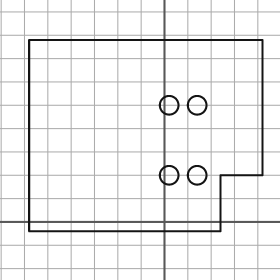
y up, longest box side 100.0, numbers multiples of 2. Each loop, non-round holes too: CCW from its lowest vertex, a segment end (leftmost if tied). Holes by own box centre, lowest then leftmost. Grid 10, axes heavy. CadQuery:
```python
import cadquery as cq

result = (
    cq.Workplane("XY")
    .moveTo(-58.0, -4.0)
    .lineTo(24.0, -4.0)
    .lineTo(24.0, 20.0)
    .lineTo(42.0, 20.0)
    .lineTo(42.0, 78.0)
    .lineTo(-58.0, 78.0)
    .close()
    .moveTo(2.0, 20.0)
    .circle(4.0)
    .moveTo(14.0, 20.0)
    .circle(4.0)
    .moveTo(2.0, 50.0)
    .circle(4.0)
    .moveTo(14.0, 50.0)
    .circle(4.0)
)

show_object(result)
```